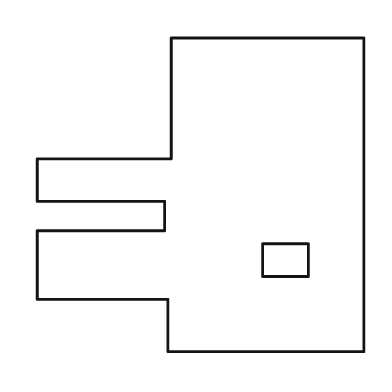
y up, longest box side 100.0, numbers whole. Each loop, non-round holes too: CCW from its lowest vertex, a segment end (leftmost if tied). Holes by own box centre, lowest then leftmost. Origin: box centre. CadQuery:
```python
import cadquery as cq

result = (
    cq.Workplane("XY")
    .moveTo(-10.0, -48.0)
    .lineTo(50.0, -48.0)
    .lineTo(50.0, 48.0)
    .lineTo(-9.0, 48.0)
    .lineTo(-9.0, 11.0)
    .lineTo(-50.0, 11.0)
    .lineTo(-50.0, -2.0)
    .lineTo(-11.0, -2.0)
    .lineTo(-11.0, -11.0)
    .lineTo(-50.0, -11.0)
    .lineTo(-50.0, -32.0)
    .lineTo(-10.0, -32.0)
    .close()
    .moveTo(19.0, -25.0)
    .lineTo(33.0, -25.0)
    .lineTo(33.0, -15.0)
    .lineTo(19.0, -15.0)
    .close()
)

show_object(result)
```